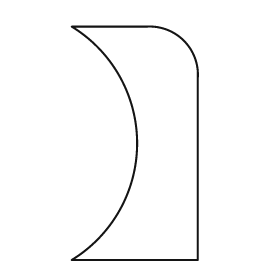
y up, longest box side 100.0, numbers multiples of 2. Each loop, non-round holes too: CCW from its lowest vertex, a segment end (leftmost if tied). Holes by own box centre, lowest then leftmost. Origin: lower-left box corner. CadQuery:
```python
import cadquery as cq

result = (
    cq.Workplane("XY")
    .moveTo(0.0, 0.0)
    .lineTo(54.0, 0.0)
    .lineTo(54.0, 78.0)
    .threePointArc((48.0, 94.0), (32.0, 100.0))
    .lineTo(0.0, 100.0)
    .threePointArc((28.0, 50.0), (0.0, 0.0))
    .close()
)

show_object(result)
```